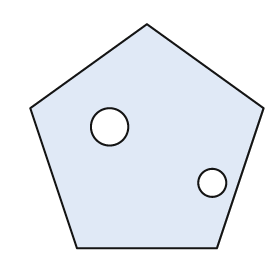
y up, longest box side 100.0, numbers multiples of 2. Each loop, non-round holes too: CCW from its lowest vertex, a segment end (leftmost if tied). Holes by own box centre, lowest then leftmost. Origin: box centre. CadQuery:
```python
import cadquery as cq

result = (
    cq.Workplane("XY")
    .moveTo(-30.0, -48.0)
    .lineTo(30.0, -48.0)
    .lineTo(50.0, 12.0)
    .lineTo(0.0, 48.0)
    .lineTo(-50.0, 12.0)
    .close()
    .moveTo(28.0, -20.0)
    .circle(6.0)
    .moveTo(-16.0, 4.0)
    .circle(8.0)
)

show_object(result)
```